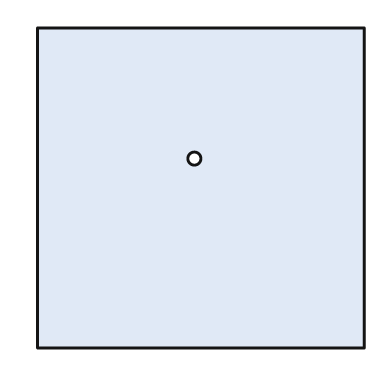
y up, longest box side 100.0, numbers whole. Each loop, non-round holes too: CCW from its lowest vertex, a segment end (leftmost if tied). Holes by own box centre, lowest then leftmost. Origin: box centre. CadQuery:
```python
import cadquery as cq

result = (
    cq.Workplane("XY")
    .moveTo(-50.0, -49.0)
    .lineTo(50.0, -49.0)
    .lineTo(50.0, 49.0)
    .lineTo(-50.0, 49.0)
    .close()
    .moveTo(-2.0, 9.0)
    .circle(2.0)
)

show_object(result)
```